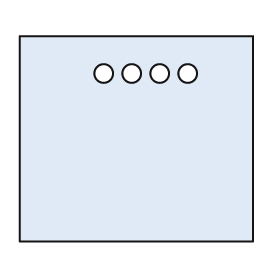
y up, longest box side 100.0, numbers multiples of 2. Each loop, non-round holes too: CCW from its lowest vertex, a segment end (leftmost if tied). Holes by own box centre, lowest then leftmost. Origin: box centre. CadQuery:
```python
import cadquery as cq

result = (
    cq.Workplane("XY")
    .moveTo(-50.0, -44.0)
    .lineTo(50.0, -44.0)
    .lineTo(50.0, 44.0)
    .lineTo(-50.0, 44.0)
    .close()
    .moveTo(-14.0, 28.0)
    .circle(4.0)
    .moveTo(-2.0, 28.0)
    .circle(4.0)
    .moveTo(10.0, 28.0)
    .circle(4.0)
    .moveTo(22.0, 28.0)
    .circle(4.0)
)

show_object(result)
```